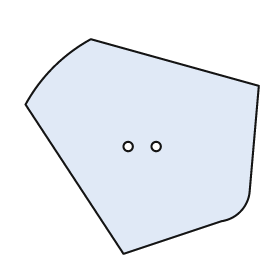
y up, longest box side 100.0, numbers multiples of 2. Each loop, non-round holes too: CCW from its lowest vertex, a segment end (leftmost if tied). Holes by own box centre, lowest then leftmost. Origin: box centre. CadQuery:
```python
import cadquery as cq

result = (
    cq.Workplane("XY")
    .moveTo(-8.0, -46.0)
    .lineTo(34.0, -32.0)
    .threePointArc((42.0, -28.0), (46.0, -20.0))
    .lineTo(50.0, 26.0)
    .lineTo(-22.0, 46.0)
    .threePointArc((-38.0, 34.0), (-50.0, 18.0))
    .close()
    .moveTo(-6.0, 0.0)
    .circle(2.0)
    .moveTo(6.0, 0.0)
    .circle(2.0)
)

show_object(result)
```